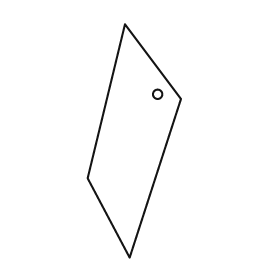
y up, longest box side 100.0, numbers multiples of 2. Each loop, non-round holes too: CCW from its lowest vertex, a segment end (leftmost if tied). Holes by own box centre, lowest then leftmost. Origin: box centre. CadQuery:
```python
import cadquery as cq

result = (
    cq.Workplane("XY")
    .moveTo(-2.0, -50.0)
    .lineTo(20.0, 18.0)
    .lineTo(-4.0, 50.0)
    .lineTo(-20.0, -16.0)
    .close()
    .moveTo(10.0, 20.0)
    .circle(2.0)
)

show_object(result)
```